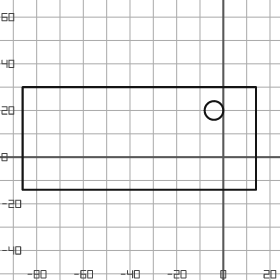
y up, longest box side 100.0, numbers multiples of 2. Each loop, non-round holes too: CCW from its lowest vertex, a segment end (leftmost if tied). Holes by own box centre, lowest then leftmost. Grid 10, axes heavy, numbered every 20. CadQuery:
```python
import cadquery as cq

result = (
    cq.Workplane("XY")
    .moveTo(-86.0, -14.0)
    .lineTo(14.0, -14.0)
    .lineTo(14.0, 30.0)
    .lineTo(-86.0, 30.0)
    .close()
    .moveTo(-4.0, 20.0)
    .circle(4.0)
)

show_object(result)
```